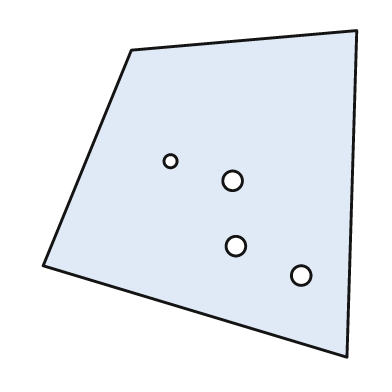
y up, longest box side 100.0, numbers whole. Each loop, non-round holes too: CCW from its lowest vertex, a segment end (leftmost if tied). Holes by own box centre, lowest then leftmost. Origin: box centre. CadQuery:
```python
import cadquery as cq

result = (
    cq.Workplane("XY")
    .moveTo(45.0, -50.0)
    .lineTo(48.0, 50.0)
    .lineTo(-21.0, 44.0)
    .lineTo(-48.0, -22.0)
    .close()
    .moveTo(31.0, -25.0)
    .circle(3.0)
    .moveTo(11.0, -16.0)
    .circle(3.0)
    .moveTo(10.0, 4.0)
    .circle(3.0)
    .moveTo(-9.0, 10.0)
    .circle(2.0)
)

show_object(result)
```